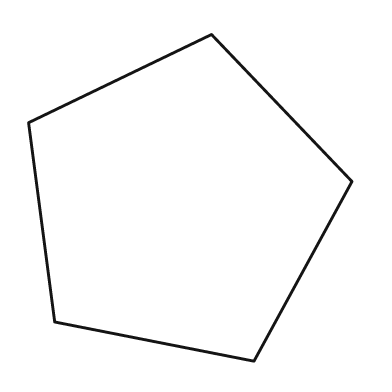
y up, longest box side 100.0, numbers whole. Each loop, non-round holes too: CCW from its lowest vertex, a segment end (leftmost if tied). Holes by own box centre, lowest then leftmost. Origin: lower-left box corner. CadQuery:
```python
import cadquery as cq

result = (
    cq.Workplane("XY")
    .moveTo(69.0, 0.0)
    .lineTo(99.0, 55.0)
    .lineTo(56.0, 100.0)
    .lineTo(0.0, 73.0)
    .lineTo(8.0, 12.0)
    .close()
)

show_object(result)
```